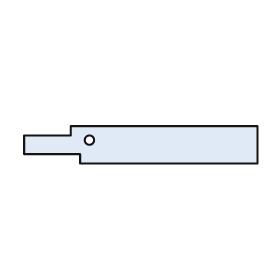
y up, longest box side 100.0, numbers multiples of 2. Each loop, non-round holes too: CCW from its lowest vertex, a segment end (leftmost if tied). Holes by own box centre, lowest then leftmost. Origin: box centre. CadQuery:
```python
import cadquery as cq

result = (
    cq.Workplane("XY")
    .moveTo(-26.0, -8.0)
    .lineTo(50.0, -8.0)
    .lineTo(50.0, 8.0)
    .lineTo(-30.0, 8.0)
    .lineTo(-30.0, 4.0)
    .lineTo(-50.0, 4.0)
    .lineTo(-50.0, -4.0)
    .lineTo(-26.0, -4.0)
    .close()
    .moveTo(-22.0, 2.0)
    .circle(2.0)
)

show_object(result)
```